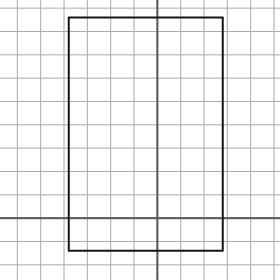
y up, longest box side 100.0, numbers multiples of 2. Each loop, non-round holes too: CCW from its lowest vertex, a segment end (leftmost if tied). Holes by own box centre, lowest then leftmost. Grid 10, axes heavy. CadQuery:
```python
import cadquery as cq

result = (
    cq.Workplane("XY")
    .moveTo(-38.0, -14.0)
    .lineTo(28.0, -14.0)
    .lineTo(28.0, 86.0)
    .lineTo(-38.0, 86.0)
    .close()
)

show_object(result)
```